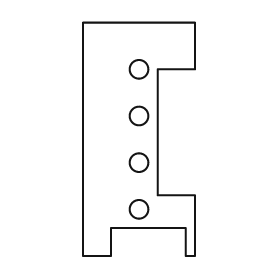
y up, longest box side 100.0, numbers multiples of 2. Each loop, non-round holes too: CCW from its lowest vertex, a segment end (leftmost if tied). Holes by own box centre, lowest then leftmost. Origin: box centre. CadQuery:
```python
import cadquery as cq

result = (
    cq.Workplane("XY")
    .moveTo(-24.0, -50.0)
    .lineTo(-12.0, -50.0)
    .lineTo(-12.0, -38.0)
    .lineTo(20.0, -38.0)
    .lineTo(20.0, -50.0)
    .lineTo(24.0, -50.0)
    .lineTo(24.0, -24.0)
    .lineTo(8.0, -24.0)
    .lineTo(8.0, 30.0)
    .lineTo(24.0, 30.0)
    .lineTo(24.0, 50.0)
    .lineTo(-24.0, 50.0)
    .close()
    .moveTo(0.0, -30.0)
    .circle(4.0)
    .moveTo(0.0, -10.0)
    .circle(4.0)
    .moveTo(0.0, 10.0)
    .circle(4.0)
    .moveTo(0.0, 30.0)
    .circle(4.0)
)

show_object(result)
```